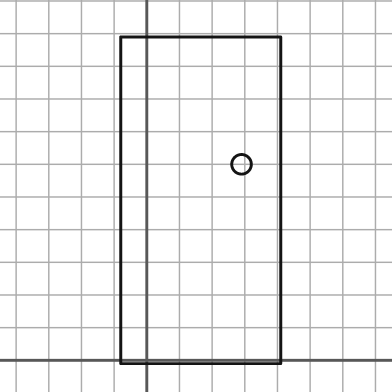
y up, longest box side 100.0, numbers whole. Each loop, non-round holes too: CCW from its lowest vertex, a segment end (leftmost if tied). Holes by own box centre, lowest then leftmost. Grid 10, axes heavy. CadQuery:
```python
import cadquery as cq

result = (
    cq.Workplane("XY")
    .moveTo(-8.0, -1.0)
    .lineTo(41.0, -1.0)
    .lineTo(41.0, 99.0)
    .lineTo(-8.0, 99.0)
    .close()
    .moveTo(29.0, 60.0)
    .circle(3.0)
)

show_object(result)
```